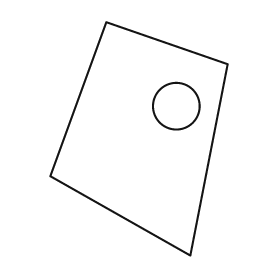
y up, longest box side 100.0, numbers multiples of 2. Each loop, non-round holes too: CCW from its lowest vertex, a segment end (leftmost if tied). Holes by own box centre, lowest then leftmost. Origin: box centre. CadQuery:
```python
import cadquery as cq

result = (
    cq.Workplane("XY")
    .moveTo(22.0, -50.0)
    .lineTo(38.0, 32.0)
    .lineTo(-14.0, 50.0)
    .lineTo(-38.0, -16.0)
    .close()
    .moveTo(16.0, 14.0)
    .circle(10.0)
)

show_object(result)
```